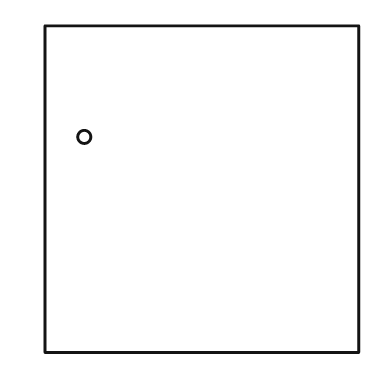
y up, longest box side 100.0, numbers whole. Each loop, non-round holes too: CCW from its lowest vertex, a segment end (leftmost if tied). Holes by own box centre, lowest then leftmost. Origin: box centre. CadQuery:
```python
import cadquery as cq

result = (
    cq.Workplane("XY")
    .moveTo(-48.0, -50.0)
    .lineTo(48.0, -50.0)
    .lineTo(48.0, 50.0)
    .lineTo(-48.0, 50.0)
    .close()
    .moveTo(-36.0, 16.0)
    .circle(2.0)
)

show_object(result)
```